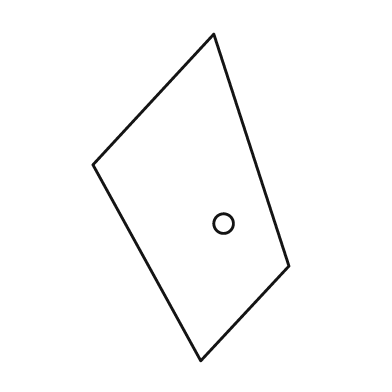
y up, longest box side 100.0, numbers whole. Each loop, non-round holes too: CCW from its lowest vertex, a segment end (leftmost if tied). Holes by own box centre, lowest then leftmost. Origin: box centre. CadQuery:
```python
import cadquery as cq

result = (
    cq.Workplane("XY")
    .moveTo(3.0, -50.0)
    .lineTo(30.0, -21.0)
    .lineTo(7.0, 50.0)
    .lineTo(-30.0, 10.0)
    .close()
    .moveTo(10.0, -8.0)
    .circle(3.0)
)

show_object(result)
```